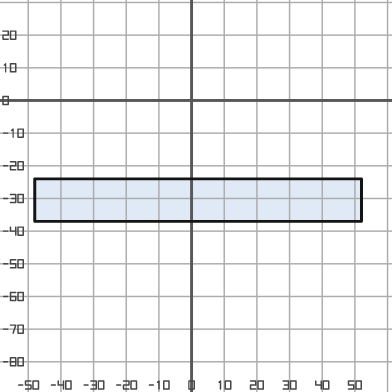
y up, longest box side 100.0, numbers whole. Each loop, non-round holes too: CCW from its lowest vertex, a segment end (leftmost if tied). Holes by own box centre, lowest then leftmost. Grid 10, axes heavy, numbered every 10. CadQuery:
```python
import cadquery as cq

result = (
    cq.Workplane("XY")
    .moveTo(-48.0, -37.0)
    .lineTo(52.0, -37.0)
    .lineTo(52.0, -24.0)
    .lineTo(-48.0, -24.0)
    .close()
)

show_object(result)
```